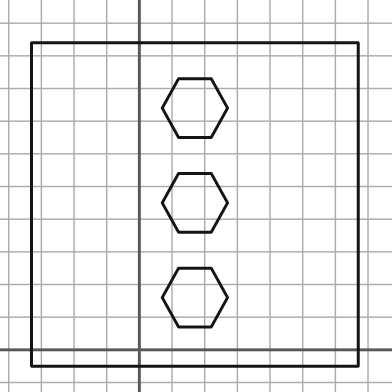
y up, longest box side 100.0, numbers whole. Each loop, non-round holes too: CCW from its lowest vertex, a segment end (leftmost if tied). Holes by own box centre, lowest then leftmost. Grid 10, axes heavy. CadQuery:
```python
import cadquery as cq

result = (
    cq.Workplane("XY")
    .moveTo(-33.0, -5.0)
    .lineTo(67.0, -5.0)
    .lineTo(67.0, 94.0)
    .lineTo(-33.0, 94.0)
    .close()
    .moveTo(12.0, 7.0)
    .lineTo(22.0, 7.0)
    .lineTo(27.0, 16.0)
    .lineTo(22.0, 25.0)
    .lineTo(12.0, 25.0)
    .lineTo(7.0, 16.0)
    .close()
    .moveTo(12.0, 36.0)
    .lineTo(22.0, 36.0)
    .lineTo(27.0, 45.0)
    .lineTo(22.0, 54.0)
    .lineTo(12.0, 54.0)
    .lineTo(7.0, 45.0)
    .close()
    .moveTo(12.0, 65.0)
    .lineTo(22.0, 65.0)
    .lineTo(27.0, 74.0)
    .lineTo(22.0, 83.0)
    .lineTo(12.0, 83.0)
    .lineTo(7.0, 74.0)
    .close()
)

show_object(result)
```